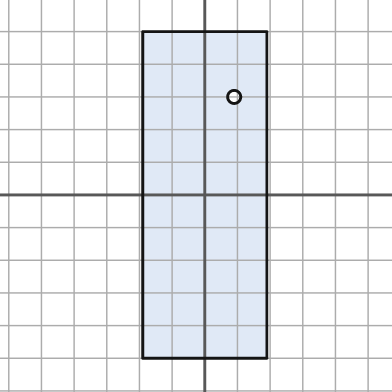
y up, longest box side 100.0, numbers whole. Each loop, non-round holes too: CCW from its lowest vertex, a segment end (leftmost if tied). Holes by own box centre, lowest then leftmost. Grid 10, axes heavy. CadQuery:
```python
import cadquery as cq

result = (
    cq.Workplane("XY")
    .moveTo(-19.0, -50.0)
    .lineTo(19.0, -50.0)
    .lineTo(19.0, 50.0)
    .lineTo(-19.0, 50.0)
    .close()
    .moveTo(9.0, 30.0)
    .circle(2.0)
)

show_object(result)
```